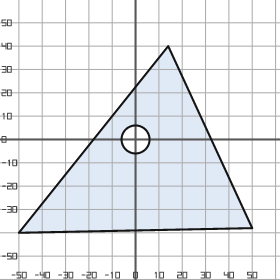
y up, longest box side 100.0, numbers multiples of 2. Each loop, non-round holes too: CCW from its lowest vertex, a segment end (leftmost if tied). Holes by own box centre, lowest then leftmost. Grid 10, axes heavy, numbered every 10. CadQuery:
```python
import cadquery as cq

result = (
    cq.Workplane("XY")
    .moveTo(-50.0, -40.0)
    .lineTo(50.0, -38.0)
    .lineTo(14.0, 40.0)
    .close()
    .moveTo(0.0, 0.0)
    .circle(6.0)
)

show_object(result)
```